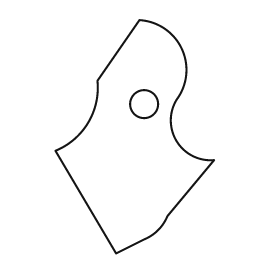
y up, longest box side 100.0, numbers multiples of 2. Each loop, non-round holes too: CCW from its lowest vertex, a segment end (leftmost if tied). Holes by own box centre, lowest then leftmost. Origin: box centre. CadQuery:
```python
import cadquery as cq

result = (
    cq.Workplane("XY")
    .moveTo(-8.0, -50.0)
    .lineTo(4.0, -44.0)
    .threePointArc((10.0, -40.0), (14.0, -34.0))
    .lineTo(34.0, -10.0)
    .threePointArc((18.0, -2.0), (18.0, 16.0))
    .threePointArc((20.0, 38.0), (2.0, 50.0))
    .lineTo(-16.0, 24.0)
    .threePointArc((-20.0, 6.0), (-34.0, -6.0))
    .close()
    .moveTo(4.0, 14.0)
    .circle(6.0)
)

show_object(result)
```